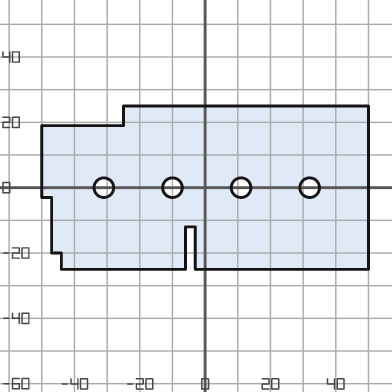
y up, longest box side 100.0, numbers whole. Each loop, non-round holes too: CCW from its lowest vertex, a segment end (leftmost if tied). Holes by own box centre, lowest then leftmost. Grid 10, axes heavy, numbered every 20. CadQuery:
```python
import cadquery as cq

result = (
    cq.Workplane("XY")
    .moveTo(-44.0, -25.0)
    .lineTo(-6.0, -25.0)
    .lineTo(-6.0, -12.0)
    .lineTo(-3.0, -12.0)
    .lineTo(-3.0, -25.0)
    .lineTo(50.0, -25.0)
    .lineTo(50.0, 25.0)
    .lineTo(-25.0, 25.0)
    .lineTo(-25.0, 19.0)
    .lineTo(-50.0, 19.0)
    .lineTo(-50.0, -3.0)
    .lineTo(-47.0, -3.0)
    .lineTo(-47.0, -20.0)
    .lineTo(-44.0, -20.0)
    .close()
    .moveTo(-31.0, 0.0)
    .circle(3.0)
    .moveTo(-10.0, 0.0)
    .circle(3.0)
    .moveTo(11.0, 0.0)
    .circle(3.0)
    .moveTo(32.0, 0.0)
    .circle(3.0)
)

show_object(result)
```